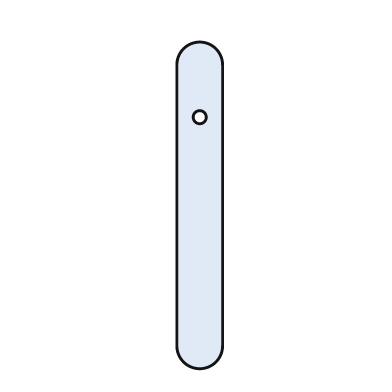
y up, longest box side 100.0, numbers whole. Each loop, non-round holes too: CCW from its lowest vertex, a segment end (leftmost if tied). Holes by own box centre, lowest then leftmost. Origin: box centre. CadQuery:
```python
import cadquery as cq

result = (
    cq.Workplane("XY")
    .moveTo(-7.0, -43.0)
    .threePointArc((0.0, -50.0), (7.0, -43.0))
    .lineTo(7.0, 43.0)
    .threePointArc((0.0, 50.0), (-7.0, 43.0))
    .close()
    .moveTo(0.0, 27.0)
    .circle(2.0)
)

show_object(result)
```